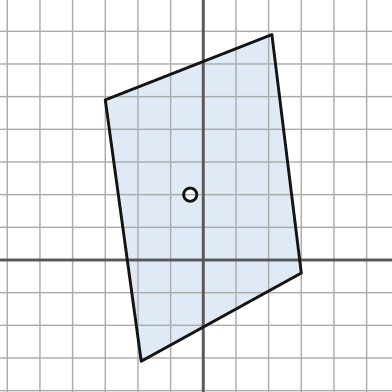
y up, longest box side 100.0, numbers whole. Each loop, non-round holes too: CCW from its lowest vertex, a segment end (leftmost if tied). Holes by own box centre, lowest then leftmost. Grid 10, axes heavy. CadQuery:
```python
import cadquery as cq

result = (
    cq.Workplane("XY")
    .moveTo(-19.0, -31.0)
    .lineTo(30.0, -4.0)
    .lineTo(21.0, 69.0)
    .lineTo(-30.0, 49.0)
    .close()
    .moveTo(-4.0, 20.0)
    .circle(2.0)
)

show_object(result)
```